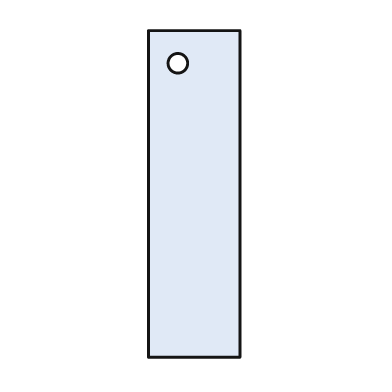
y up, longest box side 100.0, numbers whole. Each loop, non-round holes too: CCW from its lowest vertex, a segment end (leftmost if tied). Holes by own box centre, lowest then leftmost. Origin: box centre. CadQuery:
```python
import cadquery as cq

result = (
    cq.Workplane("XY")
    .moveTo(-14.0, -50.0)
    .lineTo(14.0, -50.0)
    .lineTo(14.0, 50.0)
    .lineTo(-14.0, 50.0)
    .close()
    .moveTo(-5.0, 40.0)
    .circle(3.0)
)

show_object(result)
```